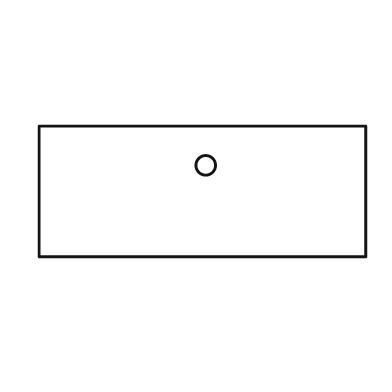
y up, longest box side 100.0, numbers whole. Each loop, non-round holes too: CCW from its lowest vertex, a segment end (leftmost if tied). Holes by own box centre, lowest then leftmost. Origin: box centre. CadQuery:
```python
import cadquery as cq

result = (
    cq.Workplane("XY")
    .moveTo(-50.0, -20.0)
    .lineTo(50.0, -20.0)
    .lineTo(50.0, 20.0)
    .lineTo(-50.0, 20.0)
    .close()
    .moveTo(1.0, 8.0)
    .circle(3.0)
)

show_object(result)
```